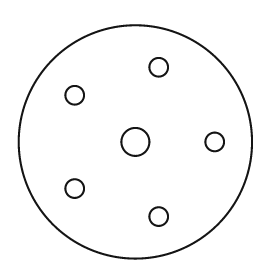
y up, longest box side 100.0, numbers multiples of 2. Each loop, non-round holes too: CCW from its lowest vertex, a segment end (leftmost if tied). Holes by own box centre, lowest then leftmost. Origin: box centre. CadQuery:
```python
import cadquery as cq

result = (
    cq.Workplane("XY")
    .moveTo(0.0, 0.0)
    .circle(50.0)
    .moveTo(10.0, -32.0)
    .circle(4.0)
    .moveTo(-26.0, -20.0)
    .circle(4.0)
    .moveTo(0.0, 0.0)
    .circle(6.0)
    .moveTo(34.0, 0.0)
    .circle(4.0)
    .moveTo(-26.0, 20.0)
    .circle(4.0)
    .moveTo(10.0, 32.0)
    .circle(4.0)
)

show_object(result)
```